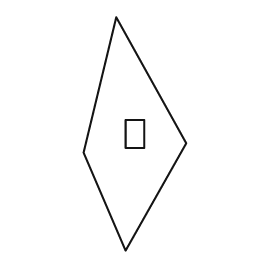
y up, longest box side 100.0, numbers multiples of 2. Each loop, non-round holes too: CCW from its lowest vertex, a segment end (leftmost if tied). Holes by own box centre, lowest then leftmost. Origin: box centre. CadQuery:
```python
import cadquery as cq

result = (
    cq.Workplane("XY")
    .moveTo(-4.0, -50.0)
    .lineTo(22.0, -4.0)
    .lineTo(-8.0, 50.0)
    .lineTo(-22.0, -8.0)
    .close()
    .moveTo(-4.0, -6.0)
    .lineTo(4.0, -6.0)
    .lineTo(4.0, 6.0)
    .lineTo(-4.0, 6.0)
    .close()
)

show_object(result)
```